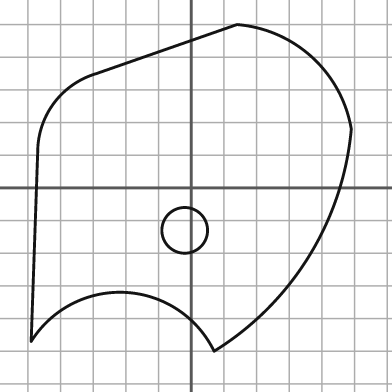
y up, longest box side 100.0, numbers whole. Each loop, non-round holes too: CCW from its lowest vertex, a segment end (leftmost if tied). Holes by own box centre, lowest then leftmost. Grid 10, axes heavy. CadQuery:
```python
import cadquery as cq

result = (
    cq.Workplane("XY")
    .moveTo(7.0, -50.0)
    .threePointArc((36.0, -21.0), (49.0, 18.0))
    .threePointArc((37.0, 40.0), (14.0, 50.0))
    .lineTo(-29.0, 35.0)
    .threePointArc((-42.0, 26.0), (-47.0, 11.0))
    .lineTo(-49.0, -47.0)
    .threePointArc((-20.0, -32.0), (7.0, -50.0))
    .close()
    .moveTo(-2.0, -13.0)
    .circle(7.0)
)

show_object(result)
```